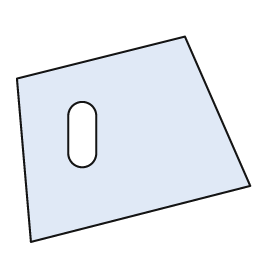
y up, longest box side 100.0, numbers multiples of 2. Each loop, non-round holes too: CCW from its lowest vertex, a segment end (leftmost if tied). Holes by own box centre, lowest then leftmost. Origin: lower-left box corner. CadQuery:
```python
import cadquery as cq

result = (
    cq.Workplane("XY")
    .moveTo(6.0, 0.0)
    .lineTo(100.0, 24.0)
    .lineTo(72.0, 88.0)
    .lineTo(0.0, 70.0)
    .close()
    .moveTo(22.0, 38.0)
    .threePointArc((28.0, 32.0), (34.0, 38.0))
    .lineTo(34.0, 54.0)
    .threePointArc((28.0, 60.0), (22.0, 54.0))
    .close()
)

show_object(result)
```